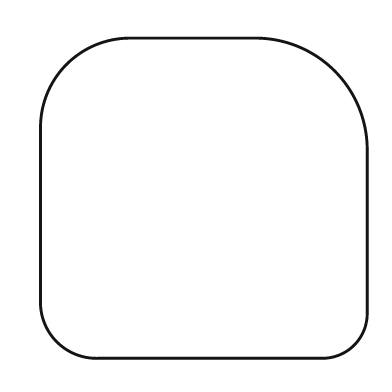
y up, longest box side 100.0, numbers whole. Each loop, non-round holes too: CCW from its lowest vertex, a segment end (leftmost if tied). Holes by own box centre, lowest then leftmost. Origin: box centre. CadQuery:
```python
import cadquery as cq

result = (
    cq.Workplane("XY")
    .moveTo(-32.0, -49.0)
    .lineTo(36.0, -49.0)
    .threePointArc((46.0, -45.0), (50.0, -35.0))
    .lineTo(50.0, 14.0)
    .threePointArc((40.0, 39.0), (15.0, 49.0))
    .lineTo(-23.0, 49.0)
    .threePointArc((-42.0, 41.0), (-50.0, 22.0))
    .lineTo(-50.0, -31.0)
    .threePointArc((-45.0, -44.0), (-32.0, -49.0))
    .close()
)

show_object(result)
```